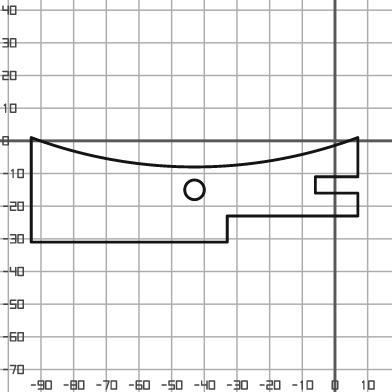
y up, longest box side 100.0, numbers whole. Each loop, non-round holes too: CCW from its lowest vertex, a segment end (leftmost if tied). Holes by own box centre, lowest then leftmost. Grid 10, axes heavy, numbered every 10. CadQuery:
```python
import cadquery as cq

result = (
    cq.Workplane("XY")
    .moveTo(-93.0, -31.0)
    .lineTo(-33.0, -31.0)
    .lineTo(-33.0, -23.0)
    .lineTo(7.0, -23.0)
    .lineTo(7.0, -16.0)
    .lineTo(-6.0, -16.0)
    .lineTo(-6.0, -11.0)
    .lineTo(7.0, -11.0)
    .lineTo(7.0, 1.0)
    .threePointArc((-43.0, -8.0), (-93.0, 1.0))
    .close()
    .moveTo(-43.0, -15.0)
    .circle(3.0)
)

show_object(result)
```